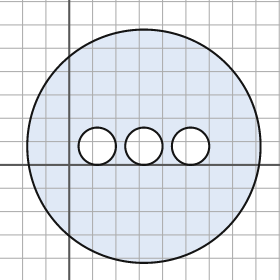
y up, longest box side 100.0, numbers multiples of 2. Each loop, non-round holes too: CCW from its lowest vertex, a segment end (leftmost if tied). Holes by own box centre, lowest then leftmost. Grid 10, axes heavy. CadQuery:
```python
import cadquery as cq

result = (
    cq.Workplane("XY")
    .moveTo(32.0, 8.0)
    .circle(50.0)
    .moveTo(12.0, 8.0)
    .circle(8.0)
    .moveTo(32.0, 8.0)
    .circle(8.0)
    .moveTo(52.0, 8.0)
    .circle(8.0)
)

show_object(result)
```